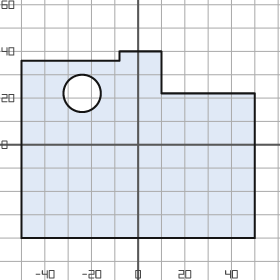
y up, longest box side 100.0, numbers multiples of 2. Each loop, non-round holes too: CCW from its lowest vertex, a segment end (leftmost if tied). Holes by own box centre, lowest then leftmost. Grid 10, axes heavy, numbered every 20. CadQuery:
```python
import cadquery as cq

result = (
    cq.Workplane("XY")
    .moveTo(-50.0, -40.0)
    .lineTo(50.0, -40.0)
    .lineTo(50.0, 22.0)
    .lineTo(10.0, 22.0)
    .lineTo(10.0, 40.0)
    .lineTo(-8.0, 40.0)
    .lineTo(-8.0, 36.0)
    .lineTo(-50.0, 36.0)
    .close()
    .moveTo(-24.0, 22.0)
    .circle(8.0)
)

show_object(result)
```